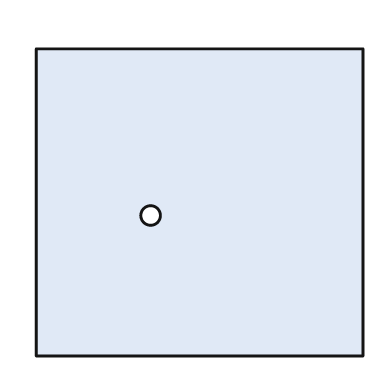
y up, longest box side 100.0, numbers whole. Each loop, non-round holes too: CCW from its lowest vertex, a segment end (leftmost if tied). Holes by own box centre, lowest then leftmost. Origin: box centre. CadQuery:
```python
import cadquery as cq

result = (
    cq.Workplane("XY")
    .moveTo(-50.0, -47.0)
    .lineTo(50.0, -47.0)
    .lineTo(50.0, 47.0)
    .lineTo(-50.0, 47.0)
    .close()
    .moveTo(-15.0, -4.0)
    .circle(3.0)
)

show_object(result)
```